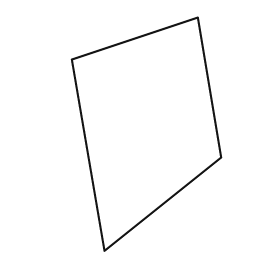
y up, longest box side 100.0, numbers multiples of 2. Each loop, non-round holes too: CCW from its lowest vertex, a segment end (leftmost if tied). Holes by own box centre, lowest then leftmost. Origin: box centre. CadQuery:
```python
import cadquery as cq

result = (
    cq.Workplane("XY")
    .moveTo(-18.0, -50.0)
    .lineTo(32.0, -10.0)
    .lineTo(22.0, 50.0)
    .lineTo(-32.0, 32.0)
    .close()
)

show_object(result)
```